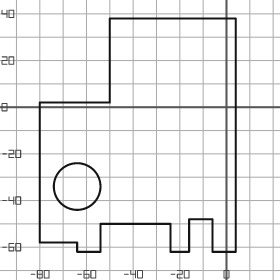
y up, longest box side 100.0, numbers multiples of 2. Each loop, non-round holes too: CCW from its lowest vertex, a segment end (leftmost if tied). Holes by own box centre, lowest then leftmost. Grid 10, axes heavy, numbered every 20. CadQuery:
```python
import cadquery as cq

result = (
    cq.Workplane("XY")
    .moveTo(-64.0, -62.0)
    .lineTo(-54.0, -62.0)
    .lineTo(-54.0, -50.0)
    .lineTo(-24.0, -50.0)
    .lineTo(-24.0, -62.0)
    .lineTo(-16.0, -62.0)
    .lineTo(-16.0, -48.0)
    .lineTo(-6.0, -48.0)
    .lineTo(-6.0, -62.0)
    .lineTo(4.0, -62.0)
    .lineTo(4.0, 38.0)
    .lineTo(-50.0, 38.0)
    .lineTo(-50.0, 2.0)
    .lineTo(-80.0, 2.0)
    .lineTo(-80.0, -58.0)
    .lineTo(-64.0, -58.0)
    .close()
    .moveTo(-64.0, -34.0)
    .circle(10.0)
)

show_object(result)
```